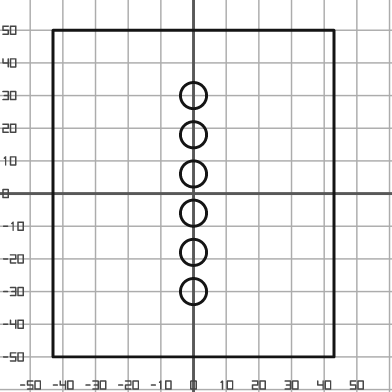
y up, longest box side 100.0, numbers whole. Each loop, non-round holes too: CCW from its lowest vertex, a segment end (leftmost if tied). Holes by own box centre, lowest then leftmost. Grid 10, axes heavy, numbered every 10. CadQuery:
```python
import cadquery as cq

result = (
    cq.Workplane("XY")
    .moveTo(-43.0, -50.0)
    .lineTo(43.0, -50.0)
    .lineTo(43.0, 50.0)
    .lineTo(-43.0, 50.0)
    .close()
    .moveTo(0.0, -30.0)
    .circle(4.0)
    .moveTo(0.0, -18.0)
    .circle(4.0)
    .moveTo(0.0, -6.0)
    .circle(4.0)
    .moveTo(0.0, 6.0)
    .circle(4.0)
    .moveTo(0.0, 18.0)
    .circle(4.0)
    .moveTo(0.0, 30.0)
    .circle(4.0)
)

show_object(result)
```